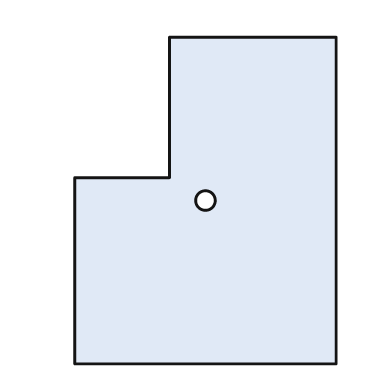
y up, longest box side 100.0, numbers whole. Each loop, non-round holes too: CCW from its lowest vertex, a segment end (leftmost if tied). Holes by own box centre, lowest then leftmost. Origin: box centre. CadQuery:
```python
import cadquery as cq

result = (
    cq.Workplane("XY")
    .moveTo(-40.0, -50.0)
    .lineTo(40.0, -50.0)
    .lineTo(40.0, 50.0)
    .lineTo(-11.0, 50.0)
    .lineTo(-11.0, 7.0)
    .lineTo(-40.0, 7.0)
    .close()
    .moveTo(0.0, 0.0)
    .circle(3.0)
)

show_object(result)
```